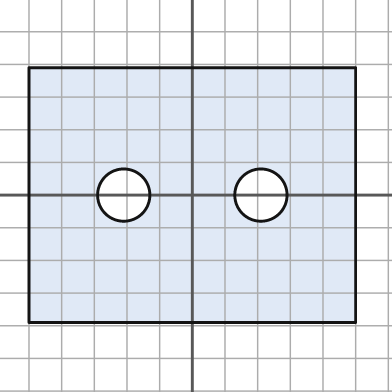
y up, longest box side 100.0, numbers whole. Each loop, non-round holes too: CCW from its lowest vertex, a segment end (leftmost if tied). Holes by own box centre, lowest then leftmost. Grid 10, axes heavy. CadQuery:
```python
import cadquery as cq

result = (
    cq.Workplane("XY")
    .moveTo(-50.0, -39.0)
    .lineTo(50.0, -39.0)
    .lineTo(50.0, 39.0)
    .lineTo(-50.0, 39.0)
    .close()
    .moveTo(-21.0, 0.0)
    .circle(8.0)
    .moveTo(21.0, 0.0)
    .circle(8.0)
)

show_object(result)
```